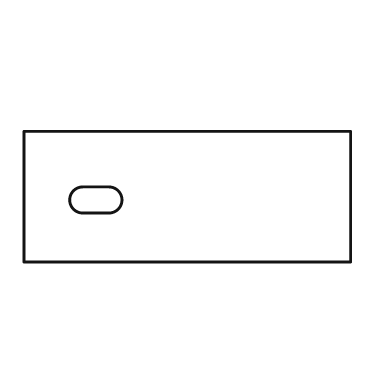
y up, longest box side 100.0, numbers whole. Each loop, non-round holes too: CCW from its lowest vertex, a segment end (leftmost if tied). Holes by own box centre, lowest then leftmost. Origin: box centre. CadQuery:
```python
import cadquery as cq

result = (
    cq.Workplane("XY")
    .moveTo(-50.0, -20.0)
    .lineTo(50.0, -20.0)
    .lineTo(50.0, 20.0)
    .lineTo(-50.0, 20.0)
    .close()
    .moveTo(-32.0, -5.0)
    .lineTo(-24.0, -5.0)
    .threePointArc((-20.0, -1.0), (-24.0, 3.0))
    .lineTo(-32.0, 3.0)
    .threePointArc((-36.0, -1.0), (-32.0, -5.0))
    .close()
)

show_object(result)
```